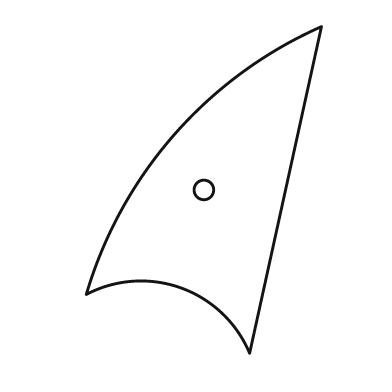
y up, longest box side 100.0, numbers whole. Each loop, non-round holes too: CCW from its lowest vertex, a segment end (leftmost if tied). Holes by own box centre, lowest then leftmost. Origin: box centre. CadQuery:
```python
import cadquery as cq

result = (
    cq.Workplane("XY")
    .moveTo(14.0, -50.0)
    .lineTo(36.0, 50.0)
    .threePointArc((-9.0, 17.0), (-36.0, -32.0))
    .threePointArc((-7.0, -30.0), (14.0, -50.0))
    .close()
    .moveTo(0.0, 0.0)
    .circle(3.0)
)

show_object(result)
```